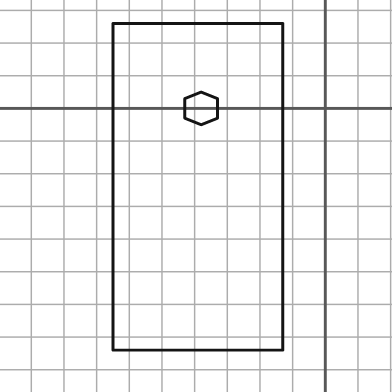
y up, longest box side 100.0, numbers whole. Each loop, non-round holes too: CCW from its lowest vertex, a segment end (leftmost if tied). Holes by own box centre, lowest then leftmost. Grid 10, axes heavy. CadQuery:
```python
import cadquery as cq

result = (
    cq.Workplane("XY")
    .moveTo(-65.0, -74.0)
    .lineTo(-13.0, -74.0)
    .lineTo(-13.0, 26.0)
    .lineTo(-65.0, 26.0)
    .close()
    .moveTo(-38.0, -5.0)
    .lineTo(-33.0, -3.0)
    .lineTo(-33.0, 3.0)
    .lineTo(-38.0, 5.0)
    .lineTo(-43.0, 3.0)
    .lineTo(-43.0, -3.0)
    .close()
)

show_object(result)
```